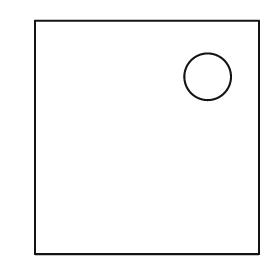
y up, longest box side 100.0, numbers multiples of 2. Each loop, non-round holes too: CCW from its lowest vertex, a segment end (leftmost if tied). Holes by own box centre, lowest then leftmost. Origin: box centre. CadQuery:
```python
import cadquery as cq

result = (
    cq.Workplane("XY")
    .moveTo(-48.0, -50.0)
    .lineTo(48.0, -50.0)
    .lineTo(48.0, 50.0)
    .lineTo(-48.0, 50.0)
    .close()
    .moveTo(26.0, 26.0)
    .circle(10.0)
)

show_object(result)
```